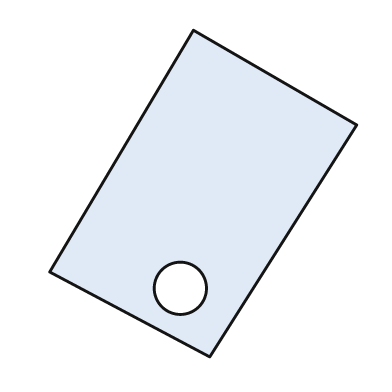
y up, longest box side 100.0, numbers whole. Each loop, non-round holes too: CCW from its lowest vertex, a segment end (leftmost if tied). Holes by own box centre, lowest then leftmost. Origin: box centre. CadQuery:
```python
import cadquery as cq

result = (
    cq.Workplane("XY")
    .moveTo(2.0, -50.0)
    .lineTo(47.0, 21.0)
    .lineTo(-3.0, 50.0)
    .lineTo(-47.0, -24.0)
    .close()
    .moveTo(-7.0, -29.0)
    .circle(8.0)
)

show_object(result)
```